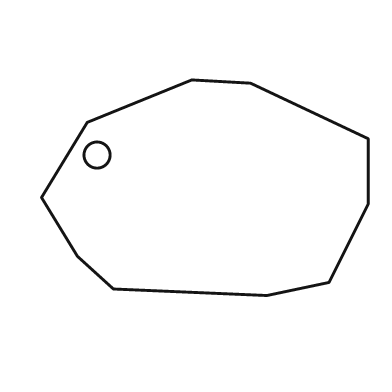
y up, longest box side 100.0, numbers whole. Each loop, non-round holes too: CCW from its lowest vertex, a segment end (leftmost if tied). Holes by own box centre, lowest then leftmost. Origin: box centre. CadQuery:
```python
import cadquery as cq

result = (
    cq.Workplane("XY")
    .moveTo(19.0, -33.0)
    .lineTo(38.0, -29.0)
    .lineTo(50.0, -5.0)
    .lineTo(50.0, 15.0)
    .lineTo(14.0, 32.0)
    .lineTo(-4.0, 33.0)
    .lineTo(-36.0, 20.0)
    .lineTo(-50.0, -3.0)
    .lineTo(-39.0, -21.0)
    .lineTo(-28.0, -31.0)
    .close()
    .moveTo(-33.0, 10.0)
    .circle(4.0)
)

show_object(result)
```